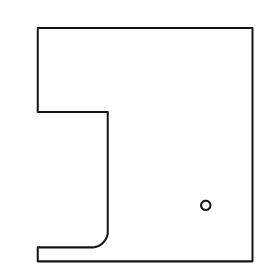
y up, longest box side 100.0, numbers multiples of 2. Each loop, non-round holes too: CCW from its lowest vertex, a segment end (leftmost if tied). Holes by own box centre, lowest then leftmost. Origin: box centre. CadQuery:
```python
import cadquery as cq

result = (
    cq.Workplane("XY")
    .moveTo(-46.0, -50.0)
    .lineTo(46.0, -50.0)
    .lineTo(46.0, 50.0)
    .lineTo(-46.0, 50.0)
    .lineTo(-46.0, 14.0)
    .lineTo(-16.0, 14.0)
    .lineTo(-16.0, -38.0)
    .threePointArc((-18.0, -42.0), (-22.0, -44.0))
    .lineTo(-46.0, -44.0)
    .close()
    .moveTo(26.0, -26.0)
    .circle(2.0)
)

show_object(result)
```